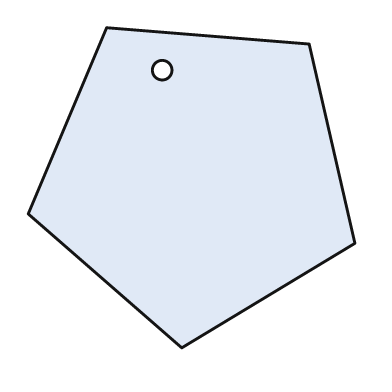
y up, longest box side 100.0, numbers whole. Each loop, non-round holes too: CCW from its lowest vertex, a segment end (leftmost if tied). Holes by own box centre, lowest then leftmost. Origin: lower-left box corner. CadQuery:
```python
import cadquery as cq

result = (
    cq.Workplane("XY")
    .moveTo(47.0, 0.0)
    .lineTo(100.0, 32.0)
    .lineTo(86.0, 93.0)
    .lineTo(24.0, 98.0)
    .lineTo(0.0, 41.0)
    .close()
    .moveTo(41.0, 85.0)
    .circle(3.0)
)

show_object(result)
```